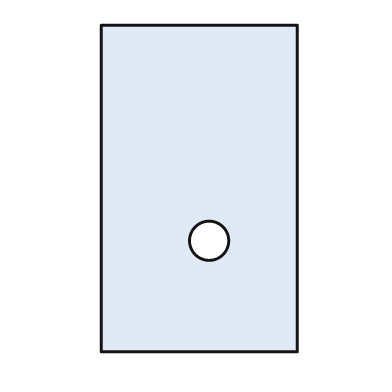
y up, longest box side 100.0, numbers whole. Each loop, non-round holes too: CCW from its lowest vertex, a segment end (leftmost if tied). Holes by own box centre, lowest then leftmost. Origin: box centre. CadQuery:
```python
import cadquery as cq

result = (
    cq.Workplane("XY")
    .moveTo(-30.0, -50.0)
    .lineTo(30.0, -50.0)
    .lineTo(30.0, 50.0)
    .lineTo(-30.0, 50.0)
    .close()
    .moveTo(3.0, -16.0)
    .circle(6.0)
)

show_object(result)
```